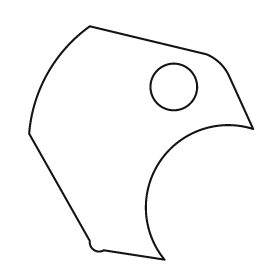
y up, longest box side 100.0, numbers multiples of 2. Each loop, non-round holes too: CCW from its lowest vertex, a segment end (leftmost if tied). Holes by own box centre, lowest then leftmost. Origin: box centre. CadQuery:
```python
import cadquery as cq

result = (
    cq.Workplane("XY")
    .moveTo(10.0, -50.0)
    .threePointArc((8.0, -8.0), (48.0, 6.0))
    .lineTo(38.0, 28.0)
    .threePointArc((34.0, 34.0), (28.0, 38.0))
    .lineTo(-22.0, 50.0)
    .threePointArc((-40.0, 30.0), (-48.0, 4.0))
    .lineTo(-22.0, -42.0)
    .threePointArc((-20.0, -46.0), (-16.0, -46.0))
    .close()
    .moveTo(14.0, 24.0)
    .circle(10.0)
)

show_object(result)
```